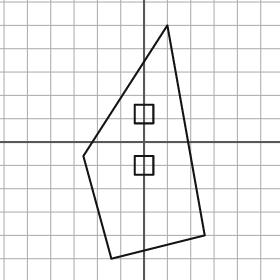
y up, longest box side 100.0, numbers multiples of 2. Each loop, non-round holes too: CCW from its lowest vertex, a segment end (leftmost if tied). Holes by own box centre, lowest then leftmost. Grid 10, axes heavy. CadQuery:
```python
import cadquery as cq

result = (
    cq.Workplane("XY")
    .moveTo(-14.0, -50.0)
    .lineTo(26.0, -40.0)
    .lineTo(10.0, 50.0)
    .lineTo(-26.0, -6.0)
    .close()
    .moveTo(-4.0, -14.0)
    .lineTo(4.0, -14.0)
    .lineTo(4.0, -6.0)
    .lineTo(-4.0, -6.0)
    .close()
    .moveTo(-4.0, 8.0)
    .lineTo(4.0, 8.0)
    .lineTo(4.0, 16.0)
    .lineTo(-4.0, 16.0)
    .close()
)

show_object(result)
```